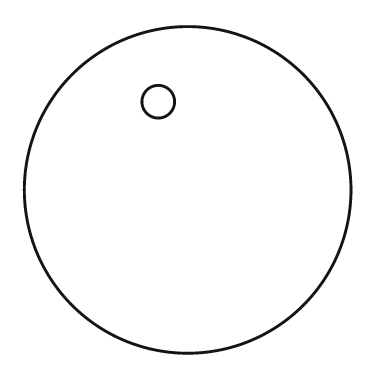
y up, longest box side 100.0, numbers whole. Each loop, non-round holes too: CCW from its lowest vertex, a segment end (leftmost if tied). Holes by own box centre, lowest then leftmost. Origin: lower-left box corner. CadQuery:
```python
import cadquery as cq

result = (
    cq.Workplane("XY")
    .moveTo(50.0, 50.0)
    .circle(50.0)
    .moveTo(41.0, 77.0)
    .circle(5.0)
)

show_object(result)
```